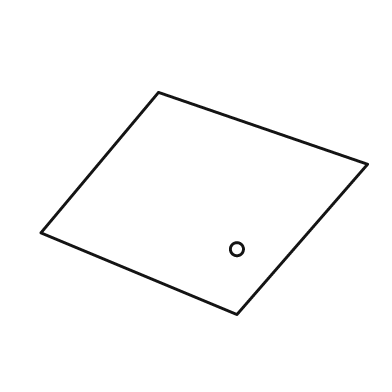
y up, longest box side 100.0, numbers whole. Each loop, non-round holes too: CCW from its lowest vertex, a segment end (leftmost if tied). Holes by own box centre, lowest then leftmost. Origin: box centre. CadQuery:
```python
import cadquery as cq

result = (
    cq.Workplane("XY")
    .moveTo(10.0, -34.0)
    .lineTo(50.0, 12.0)
    .lineTo(-14.0, 34.0)
    .lineTo(-50.0, -9.0)
    .close()
    .moveTo(10.0, -14.0)
    .circle(2.0)
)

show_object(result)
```